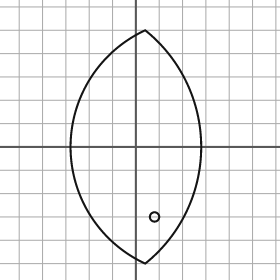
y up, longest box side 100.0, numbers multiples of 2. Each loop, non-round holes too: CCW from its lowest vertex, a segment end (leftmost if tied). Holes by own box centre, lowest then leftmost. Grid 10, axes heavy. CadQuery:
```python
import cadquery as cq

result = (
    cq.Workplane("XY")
    .moveTo(4.0, -50.0)
    .threePointArc((28.0, 0.0), (4.0, 50.0))
    .threePointArc((-28.0, 0.0), (4.0, -50.0))
    .close()
    .moveTo(8.0, -30.0)
    .circle(2.0)
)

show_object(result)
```